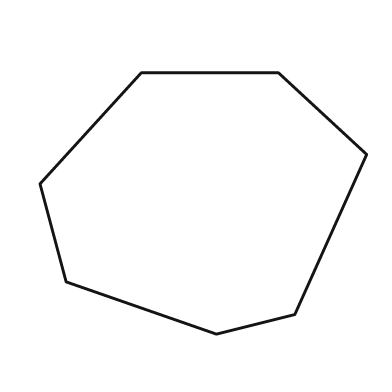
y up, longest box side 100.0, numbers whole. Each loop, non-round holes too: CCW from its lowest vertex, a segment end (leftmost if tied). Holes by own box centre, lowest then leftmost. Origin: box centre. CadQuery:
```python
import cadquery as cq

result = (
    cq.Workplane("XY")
    .moveTo(4.0, -40.0)
    .lineTo(28.0, -34.0)
    .lineTo(50.0, 15.0)
    .lineTo(23.0, 40.0)
    .lineTo(-19.0, 40.0)
    .lineTo(-50.0, 6.0)
    .lineTo(-42.0, -24.0)
    .close()
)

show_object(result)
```